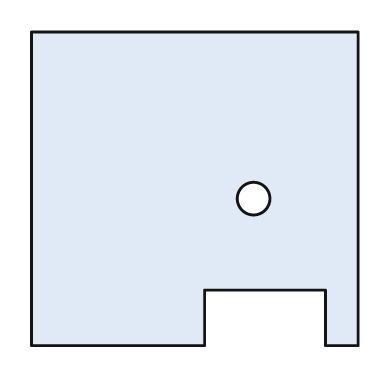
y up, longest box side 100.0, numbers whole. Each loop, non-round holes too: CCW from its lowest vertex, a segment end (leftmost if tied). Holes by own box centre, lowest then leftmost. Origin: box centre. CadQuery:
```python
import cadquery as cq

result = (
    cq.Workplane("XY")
    .moveTo(-50.0, -48.0)
    .lineTo(3.0, -48.0)
    .lineTo(3.0, -31.0)
    .lineTo(40.0, -31.0)
    .lineTo(40.0, -48.0)
    .lineTo(50.0, -48.0)
    .lineTo(50.0, 48.0)
    .lineTo(-50.0, 48.0)
    .close()
    .moveTo(18.0, -3.0)
    .circle(5.0)
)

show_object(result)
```